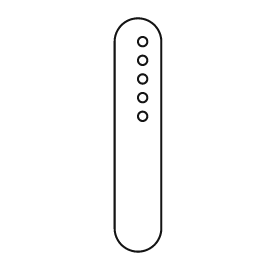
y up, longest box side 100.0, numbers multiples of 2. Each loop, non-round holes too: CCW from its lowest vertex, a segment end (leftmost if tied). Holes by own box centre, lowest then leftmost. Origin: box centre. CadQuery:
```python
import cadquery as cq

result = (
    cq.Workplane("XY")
    .moveTo(-10.0, -40.0)
    .threePointArc((0.0, -50.0), (10.0, -40.0))
    .lineTo(10.0, 40.0)
    .threePointArc((0.0, 50.0), (-10.0, 40.0))
    .close()
    .moveTo(2.0, 8.0)
    .circle(2.0)
    .moveTo(2.0, 16.0)
    .circle(2.0)
    .moveTo(2.0, 24.0)
    .circle(2.0)
    .moveTo(2.0, 32.0)
    .circle(2.0)
    .moveTo(2.0, 40.0)
    .circle(2.0)
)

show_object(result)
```